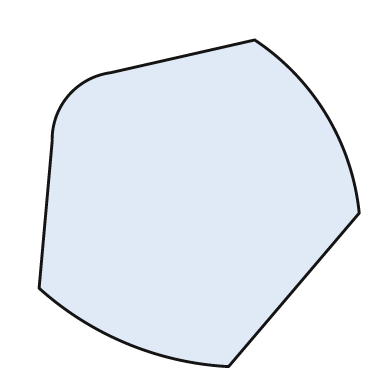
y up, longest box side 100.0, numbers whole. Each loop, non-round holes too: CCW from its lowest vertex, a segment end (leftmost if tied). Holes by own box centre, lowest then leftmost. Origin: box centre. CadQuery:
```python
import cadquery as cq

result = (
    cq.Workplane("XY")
    .moveTo(9.0, -50.0)
    .lineTo(49.0, -3.0)
    .threePointArc((39.0, 27.0), (17.0, 50.0))
    .lineTo(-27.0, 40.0)
    .threePointArc((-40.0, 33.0), (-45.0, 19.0))
    .lineTo(-49.0, -26.0)
    .threePointArc((-22.0, -43.0), (9.0, -50.0))
    .close()
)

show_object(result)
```